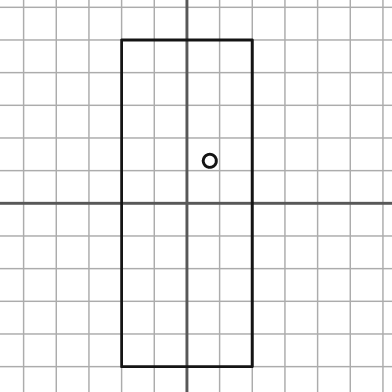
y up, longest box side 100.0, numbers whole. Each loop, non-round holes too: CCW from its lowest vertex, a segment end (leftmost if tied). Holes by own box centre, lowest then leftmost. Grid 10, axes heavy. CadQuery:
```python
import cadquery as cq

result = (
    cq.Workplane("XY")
    .moveTo(-20.0, -50.0)
    .lineTo(20.0, -50.0)
    .lineTo(20.0, 50.0)
    .lineTo(-20.0, 50.0)
    .close()
    .moveTo(7.0, 13.0)
    .circle(2.0)
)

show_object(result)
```